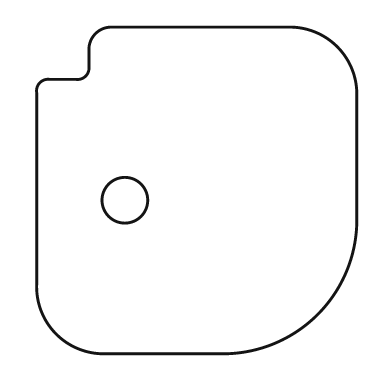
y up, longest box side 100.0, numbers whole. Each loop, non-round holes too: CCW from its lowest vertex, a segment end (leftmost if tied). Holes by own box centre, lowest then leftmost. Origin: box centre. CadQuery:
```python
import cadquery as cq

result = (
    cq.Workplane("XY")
    .moveTo(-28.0, -50.0)
    .lineTo(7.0, -50.0)
    .threePointArc((37.0, -38.0), (49.0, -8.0))
    .lineTo(49.0, 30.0)
    .threePointArc((43.0, 44.0), (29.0, 50.0))
    .lineTo(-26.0, 50.0)
    .threePointArc((-31.0, 48.0), (-33.0, 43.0))
    .lineTo(-33.0, 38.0)
    .threePointArc((-34.0, 35.0), (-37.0, 34.0))
    .lineTo(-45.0, 34.0)
    .threePointArc((-48.0, 33.0), (-49.0, 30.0))
    .lineTo(-49.0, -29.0)
    .threePointArc((-43.0, -44.0), (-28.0, -50.0))
    .close()
    .moveTo(-22.0, -3.0)
    .circle(7.0)
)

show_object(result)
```